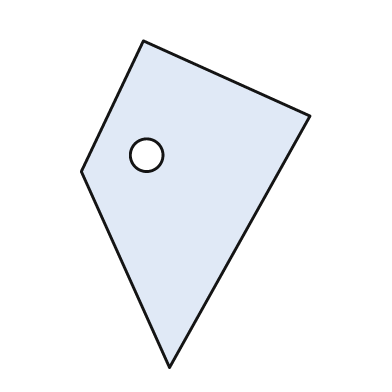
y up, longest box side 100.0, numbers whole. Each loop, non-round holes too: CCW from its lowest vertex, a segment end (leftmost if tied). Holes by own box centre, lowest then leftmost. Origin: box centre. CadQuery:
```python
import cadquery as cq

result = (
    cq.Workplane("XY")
    .moveTo(-8.0, -50.0)
    .lineTo(35.0, 27.0)
    .lineTo(-16.0, 50.0)
    .lineTo(-35.0, 10.0)
    .close()
    .moveTo(-15.0, 15.0)
    .circle(5.0)
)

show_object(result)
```